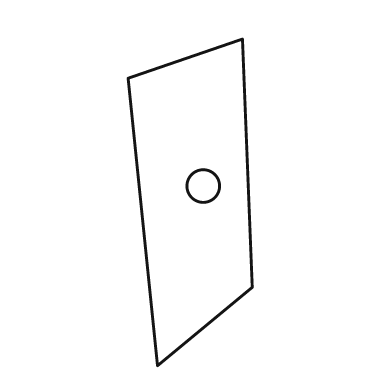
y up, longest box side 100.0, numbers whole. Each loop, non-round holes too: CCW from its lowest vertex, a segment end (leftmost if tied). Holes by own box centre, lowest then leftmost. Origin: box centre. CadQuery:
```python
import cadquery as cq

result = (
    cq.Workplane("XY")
    .moveTo(-10.0, -50.0)
    .lineTo(19.0, -26.0)
    .lineTo(16.0, 50.0)
    .lineTo(-19.0, 38.0)
    .close()
    .moveTo(4.0, 5.0)
    .circle(5.0)
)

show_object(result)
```